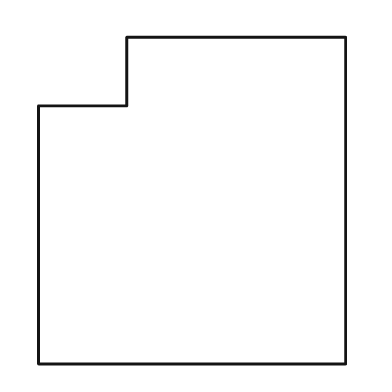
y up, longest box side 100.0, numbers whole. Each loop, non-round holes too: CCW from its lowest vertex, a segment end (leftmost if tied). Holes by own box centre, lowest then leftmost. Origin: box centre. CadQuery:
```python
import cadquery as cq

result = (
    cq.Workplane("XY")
    .moveTo(-47.0, -50.0)
    .lineTo(47.0, -50.0)
    .lineTo(47.0, 50.0)
    .lineTo(-20.0, 50.0)
    .lineTo(-20.0, 29.0)
    .lineTo(-47.0, 29.0)
    .close()
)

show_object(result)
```